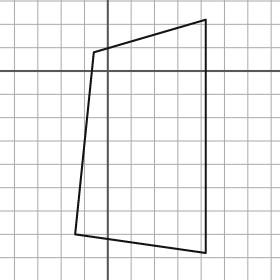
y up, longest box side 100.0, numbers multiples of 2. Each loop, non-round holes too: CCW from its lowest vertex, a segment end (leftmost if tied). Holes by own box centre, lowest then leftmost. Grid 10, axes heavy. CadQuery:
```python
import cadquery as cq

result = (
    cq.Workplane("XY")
    .moveTo(42.0, -78.0)
    .lineTo(42.0, 22.0)
    .lineTo(-6.0, 8.0)
    .lineTo(-14.0, -70.0)
    .close()
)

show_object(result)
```